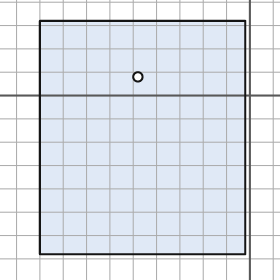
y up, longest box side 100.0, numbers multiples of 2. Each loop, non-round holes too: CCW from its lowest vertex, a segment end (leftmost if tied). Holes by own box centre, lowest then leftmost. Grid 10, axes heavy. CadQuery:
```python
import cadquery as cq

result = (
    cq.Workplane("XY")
    .moveTo(-90.0, -68.0)
    .lineTo(-2.0, -68.0)
    .lineTo(-2.0, 32.0)
    .lineTo(-90.0, 32.0)
    .close()
    .moveTo(-48.0, 8.0)
    .circle(2.0)
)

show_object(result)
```